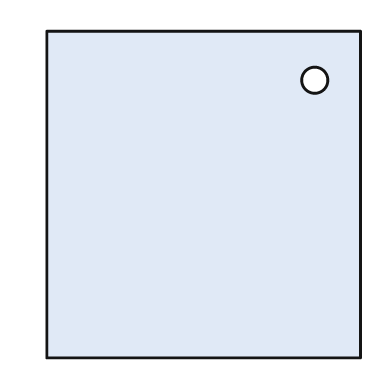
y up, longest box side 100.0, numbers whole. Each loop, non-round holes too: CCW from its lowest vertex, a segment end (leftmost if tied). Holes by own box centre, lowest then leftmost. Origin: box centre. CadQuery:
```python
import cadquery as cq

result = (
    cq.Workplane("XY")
    .moveTo(-48.0, -50.0)
    .lineTo(48.0, -50.0)
    .lineTo(48.0, 50.0)
    .lineTo(-48.0, 50.0)
    .close()
    .moveTo(34.0, 35.0)
    .circle(4.0)
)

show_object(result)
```